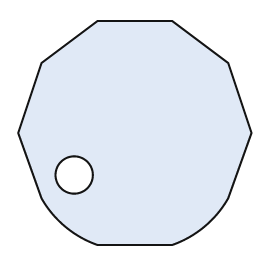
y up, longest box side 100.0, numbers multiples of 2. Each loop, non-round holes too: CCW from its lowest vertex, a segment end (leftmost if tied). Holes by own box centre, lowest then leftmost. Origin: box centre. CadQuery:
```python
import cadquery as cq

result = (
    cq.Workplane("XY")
    .moveTo(-16.0, -48.0)
    .lineTo(16.0, -48.0)
    .threePointArc((30.0, -40.0), (40.0, -28.0))
    .lineTo(50.0, 0.0)
    .lineTo(40.0, 30.0)
    .lineTo(16.0, 48.0)
    .lineTo(-16.0, 48.0)
    .lineTo(-40.0, 30.0)
    .lineTo(-50.0, 0.0)
    .lineTo(-40.0, -28.0)
    .threePointArc((-30.0, -40.0), (-16.0, -48.0))
    .close()
    .moveTo(-26.0, -18.0)
    .circle(8.0)
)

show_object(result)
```